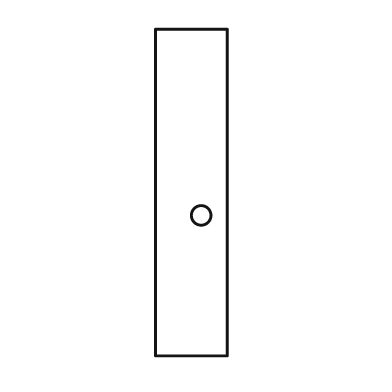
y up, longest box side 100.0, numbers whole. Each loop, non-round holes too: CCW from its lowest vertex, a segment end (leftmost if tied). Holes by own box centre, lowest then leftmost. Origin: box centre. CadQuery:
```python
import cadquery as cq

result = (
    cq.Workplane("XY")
    .moveTo(-11.0, -50.0)
    .lineTo(11.0, -50.0)
    .lineTo(11.0, 50.0)
    .lineTo(-11.0, 50.0)
    .close()
    .moveTo(3.0, -7.0)
    .circle(3.0)
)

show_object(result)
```